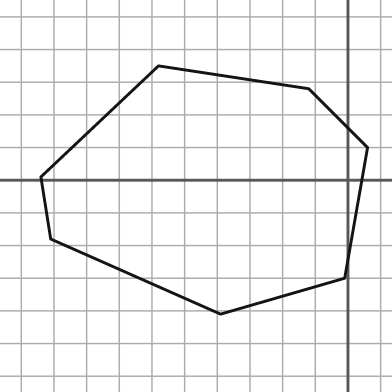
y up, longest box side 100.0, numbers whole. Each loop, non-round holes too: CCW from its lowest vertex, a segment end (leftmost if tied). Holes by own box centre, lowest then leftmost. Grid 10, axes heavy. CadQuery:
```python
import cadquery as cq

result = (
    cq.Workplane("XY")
    .moveTo(-39.0, -41.0)
    .lineTo(-1.0, -30.0)
    .lineTo(6.0, 10.0)
    .lineTo(-12.0, 28.0)
    .lineTo(-58.0, 35.0)
    .lineTo(-94.0, 1.0)
    .lineTo(-91.0, -18.0)
    .close()
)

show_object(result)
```